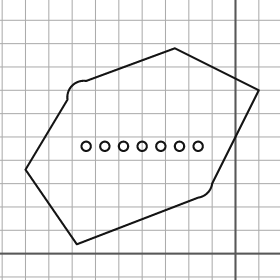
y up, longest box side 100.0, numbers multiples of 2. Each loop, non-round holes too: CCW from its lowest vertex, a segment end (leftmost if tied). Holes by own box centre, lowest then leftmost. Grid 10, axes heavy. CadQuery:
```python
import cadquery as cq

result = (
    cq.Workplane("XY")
    .moveTo(-68.0, 4.0)
    .lineTo(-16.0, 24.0)
    .threePointArc((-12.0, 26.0), (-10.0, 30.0))
    .lineTo(10.0, 70.0)
    .lineTo(-26.0, 88.0)
    .lineTo(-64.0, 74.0)
    .threePointArc((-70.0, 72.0), (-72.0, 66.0))
    .lineTo(-90.0, 36.0)
    .close()
    .moveTo(-64.0, 46.0)
    .circle(2.0)
    .moveTo(-56.0, 46.0)
    .circle(2.0)
    .moveTo(-48.0, 46.0)
    .circle(2.0)
    .moveTo(-40.0, 46.0)
    .circle(2.0)
    .moveTo(-32.0, 46.0)
    .circle(2.0)
    .moveTo(-24.0, 46.0)
    .circle(2.0)
    .moveTo(-16.0, 46.0)
    .circle(2.0)
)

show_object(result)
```